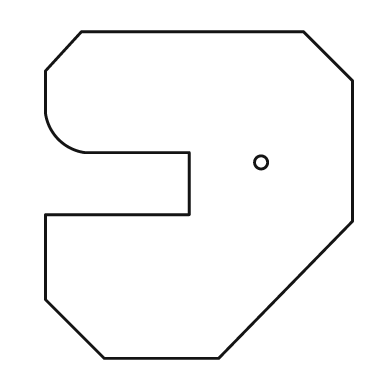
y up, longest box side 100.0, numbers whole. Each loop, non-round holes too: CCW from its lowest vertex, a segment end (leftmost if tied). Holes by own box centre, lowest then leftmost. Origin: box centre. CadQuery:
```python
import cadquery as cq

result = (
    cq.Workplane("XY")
    .moveTo(-29.0, -50.0)
    .lineTo(6.0, -50.0)
    .lineTo(47.0, -8.0)
    .lineTo(47.0, 35.0)
    .lineTo(32.0, 50.0)
    .lineTo(-36.0, 50.0)
    .lineTo(-47.0, 38.0)
    .lineTo(-47.0, 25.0)
    .threePointArc((-43.0, 17.0), (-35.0, 13.0))
    .lineTo(-3.0, 13.0)
    .lineTo(-3.0, -6.0)
    .lineTo(-47.0, -6.0)
    .lineTo(-47.0, -32.0)
    .close()
    .moveTo(19.0, 10.0)
    .circle(2.0)
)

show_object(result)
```